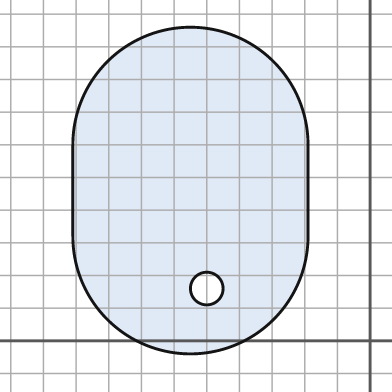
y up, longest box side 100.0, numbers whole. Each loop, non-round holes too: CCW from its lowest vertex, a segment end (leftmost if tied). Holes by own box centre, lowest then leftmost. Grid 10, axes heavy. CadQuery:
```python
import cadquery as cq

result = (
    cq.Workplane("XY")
    .moveTo(-91.0, 32.0)
    .threePointArc((-55.0, -4.0), (-19.0, 32.0))
    .lineTo(-19.0, 60.0)
    .threePointArc((-55.0, 96.0), (-91.0, 60.0))
    .close()
    .moveTo(-50.0, 16.0)
    .circle(5.0)
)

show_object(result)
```